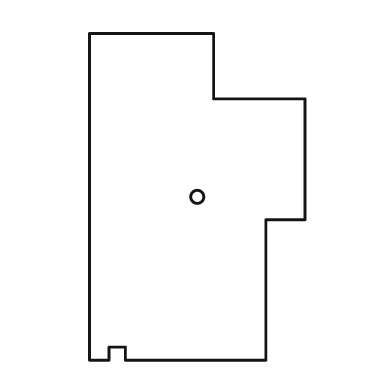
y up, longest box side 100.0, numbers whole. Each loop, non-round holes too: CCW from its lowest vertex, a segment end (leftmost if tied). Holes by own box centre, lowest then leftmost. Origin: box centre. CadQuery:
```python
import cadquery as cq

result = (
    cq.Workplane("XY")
    .moveTo(-33.0, -50.0)
    .lineTo(-27.0, -50.0)
    .lineTo(-27.0, -46.0)
    .lineTo(-22.0, -46.0)
    .lineTo(-22.0, -50.0)
    .lineTo(21.0, -50.0)
    .lineTo(21.0, -7.0)
    .lineTo(33.0, -7.0)
    .lineTo(33.0, 30.0)
    .lineTo(5.0, 30.0)
    .lineTo(5.0, 50.0)
    .lineTo(-33.0, 50.0)
    .close()
    .moveTo(0.0, 0.0)
    .circle(2.0)
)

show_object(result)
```